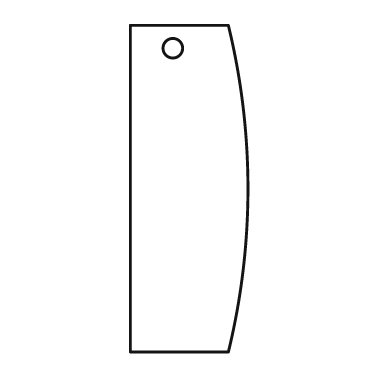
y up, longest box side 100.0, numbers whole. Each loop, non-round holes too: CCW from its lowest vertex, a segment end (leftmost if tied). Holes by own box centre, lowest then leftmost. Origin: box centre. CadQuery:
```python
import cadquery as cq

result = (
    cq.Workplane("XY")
    .moveTo(-18.0, -50.0)
    .lineTo(12.0, -50.0)
    .threePointArc((18.0, 0.0), (12.0, 50.0))
    .lineTo(-18.0, 50.0)
    .close()
    .moveTo(-5.0, 43.0)
    .circle(3.0)
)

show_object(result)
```